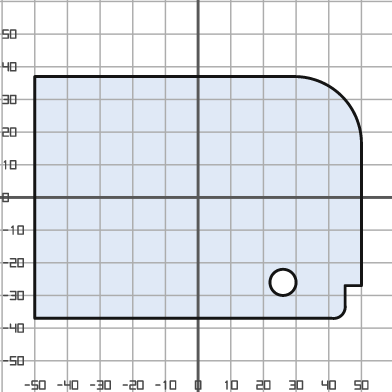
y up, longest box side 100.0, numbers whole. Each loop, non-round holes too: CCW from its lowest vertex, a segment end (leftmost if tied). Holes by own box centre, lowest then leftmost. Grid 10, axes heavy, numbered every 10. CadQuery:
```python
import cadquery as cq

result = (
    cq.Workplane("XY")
    .moveTo(-50.0, -37.0)
    .lineTo(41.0, -37.0)
    .threePointArc((44.0, -36.0), (45.0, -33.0))
    .lineTo(45.0, -27.0)
    .lineTo(50.0, -27.0)
    .lineTo(50.0, 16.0)
    .threePointArc((44.0, 31.0), (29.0, 37.0))
    .lineTo(-50.0, 37.0)
    .close()
    .moveTo(26.0, -26.0)
    .circle(4.0)
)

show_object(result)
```